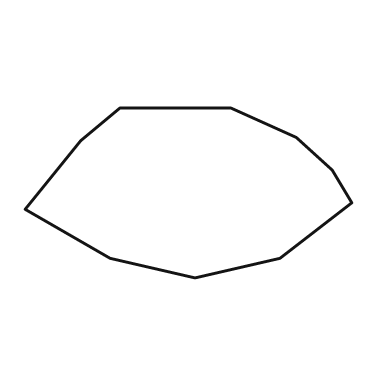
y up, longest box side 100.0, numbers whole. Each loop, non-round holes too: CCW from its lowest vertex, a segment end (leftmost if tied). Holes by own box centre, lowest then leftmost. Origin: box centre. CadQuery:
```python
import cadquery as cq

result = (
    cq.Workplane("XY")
    .moveTo(2.0, -26.0)
    .lineTo(28.0, -20.0)
    .lineTo(50.0, -3.0)
    .lineTo(44.0, 7.0)
    .lineTo(33.0, 17.0)
    .lineTo(13.0, 26.0)
    .lineTo(-21.0, 26.0)
    .lineTo(-33.0, 16.0)
    .lineTo(-50.0, -5.0)
    .lineTo(-24.0, -20.0)
    .close()
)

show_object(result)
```